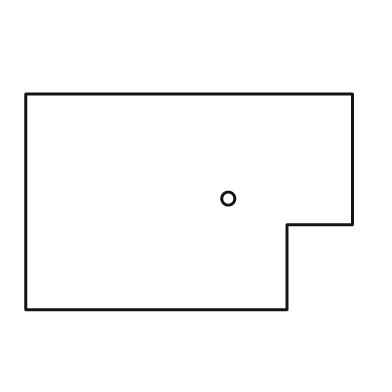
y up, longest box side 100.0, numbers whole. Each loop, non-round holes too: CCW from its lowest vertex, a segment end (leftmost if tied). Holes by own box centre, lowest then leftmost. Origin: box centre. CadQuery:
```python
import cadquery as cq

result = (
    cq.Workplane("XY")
    .moveTo(-50.0, -33.0)
    .lineTo(30.0, -33.0)
    .lineTo(30.0, -7.0)
    .lineTo(50.0, -7.0)
    .lineTo(50.0, 33.0)
    .lineTo(-50.0, 33.0)
    .close()
    .moveTo(12.0, 1.0)
    .circle(2.0)
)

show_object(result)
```